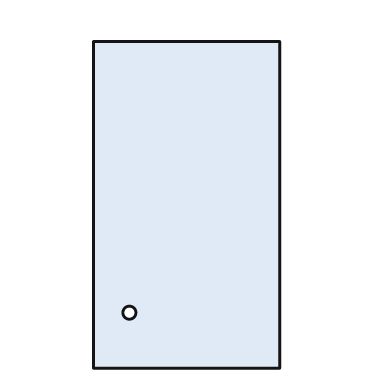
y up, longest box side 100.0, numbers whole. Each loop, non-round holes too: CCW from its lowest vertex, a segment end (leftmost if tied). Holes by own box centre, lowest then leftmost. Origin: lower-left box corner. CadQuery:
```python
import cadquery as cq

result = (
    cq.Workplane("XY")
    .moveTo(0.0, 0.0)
    .lineTo(57.0, 0.0)
    .lineTo(57.0, 100.0)
    .lineTo(0.0, 100.0)
    .close()
    .moveTo(11.0, 17.0)
    .circle(2.0)
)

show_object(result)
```